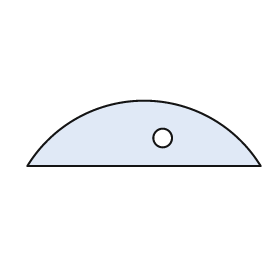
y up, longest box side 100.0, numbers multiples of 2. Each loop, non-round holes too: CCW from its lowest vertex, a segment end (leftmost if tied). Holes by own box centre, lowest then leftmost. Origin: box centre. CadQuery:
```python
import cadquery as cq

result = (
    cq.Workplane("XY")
    .moveTo(-50.0, -14.0)
    .lineTo(50.0, -14.0)
    .threePointArc((0.0, 14.0), (-50.0, -14.0))
    .close()
    .moveTo(8.0, -2.0)
    .circle(4.0)
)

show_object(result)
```